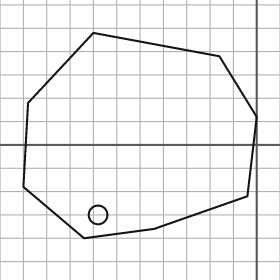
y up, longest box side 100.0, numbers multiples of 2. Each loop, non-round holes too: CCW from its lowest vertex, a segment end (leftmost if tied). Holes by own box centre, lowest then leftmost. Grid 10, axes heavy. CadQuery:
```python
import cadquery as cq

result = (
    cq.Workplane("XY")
    .moveTo(-74.0, -40.0)
    .lineTo(-44.0, -36.0)
    .lineTo(-4.0, -22.0)
    .lineTo(0.0, 12.0)
    .lineTo(-16.0, 38.0)
    .lineTo(-70.0, 48.0)
    .lineTo(-98.0, 18.0)
    .lineTo(-100.0, -18.0)
    .close()
    .moveTo(-68.0, -30.0)
    .circle(4.0)
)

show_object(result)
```